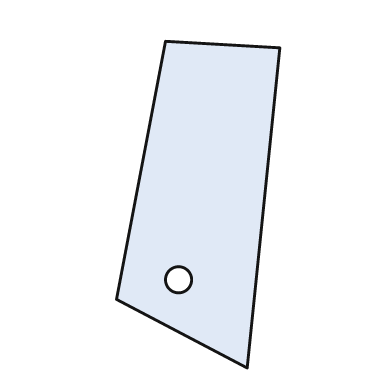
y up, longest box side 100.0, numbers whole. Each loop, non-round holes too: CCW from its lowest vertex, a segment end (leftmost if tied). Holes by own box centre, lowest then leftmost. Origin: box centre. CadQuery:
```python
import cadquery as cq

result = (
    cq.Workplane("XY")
    .moveTo(15.0, -50.0)
    .lineTo(25.0, 48.0)
    .lineTo(-10.0, 50.0)
    .lineTo(-25.0, -29.0)
    .close()
    .moveTo(-6.0, -23.0)
    .circle(4.0)
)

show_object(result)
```